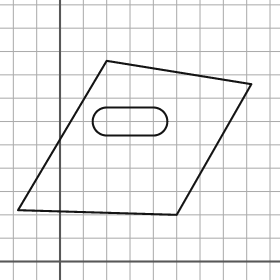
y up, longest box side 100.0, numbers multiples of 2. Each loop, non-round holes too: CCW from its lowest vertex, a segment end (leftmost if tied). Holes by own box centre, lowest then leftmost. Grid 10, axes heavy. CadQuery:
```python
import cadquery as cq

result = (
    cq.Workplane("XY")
    .moveTo(50.0, 20.0)
    .lineTo(82.0, 76.0)
    .lineTo(20.0, 86.0)
    .lineTo(-18.0, 22.0)
    .close()
    .moveTo(20.0, 54.0)
    .lineTo(40.0, 54.0)
    .threePointArc((46.0, 60.0), (40.0, 66.0))
    .lineTo(20.0, 66.0)
    .threePointArc((14.0, 60.0), (20.0, 54.0))
    .close()
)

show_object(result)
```